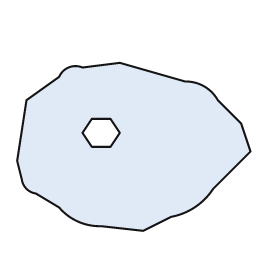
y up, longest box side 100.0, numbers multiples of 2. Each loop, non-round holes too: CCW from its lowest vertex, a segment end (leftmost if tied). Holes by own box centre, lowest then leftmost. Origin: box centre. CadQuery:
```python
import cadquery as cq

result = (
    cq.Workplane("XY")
    .moveTo(4.0, -36.0)
    .lineTo(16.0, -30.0)
    .threePointArc((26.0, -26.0), (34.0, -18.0))
    .lineTo(50.0, -2.0)
    .lineTo(46.0, 10.0)
    .lineTo(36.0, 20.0)
    .threePointArc((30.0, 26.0), (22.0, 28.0))
    .lineTo(-6.0, 36.0)
    .lineTo(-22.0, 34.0)
    .threePointArc((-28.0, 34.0), (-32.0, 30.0))
    .lineTo(-46.0, 20.0)
    .lineTo(-50.0, -6.0)
    .lineTo(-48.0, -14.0)
    .threePointArc((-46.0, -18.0), (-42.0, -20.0))
    .lineTo(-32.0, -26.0)
    .threePointArc((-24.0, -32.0), (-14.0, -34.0))
    .close()
    .moveTo(-18.0, 0.0)
    .lineTo(-10.0, 0.0)
    .lineTo(-6.0, 6.0)
    .lineTo(-10.0, 12.0)
    .lineTo(-18.0, 12.0)
    .lineTo(-22.0, 6.0)
    .close()
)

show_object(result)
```